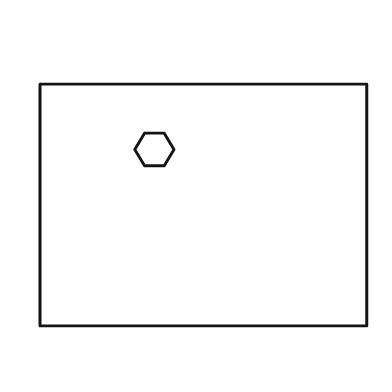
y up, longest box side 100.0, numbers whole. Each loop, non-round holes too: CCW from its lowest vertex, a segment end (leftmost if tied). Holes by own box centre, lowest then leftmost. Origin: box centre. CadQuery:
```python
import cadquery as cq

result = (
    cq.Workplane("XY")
    .moveTo(-50.0, -37.0)
    .lineTo(50.0, -37.0)
    .lineTo(50.0, 37.0)
    .lineTo(-50.0, 37.0)
    .close()
    .moveTo(-18.0, 12.0)
    .lineTo(-12.0, 12.0)
    .lineTo(-9.0, 17.0)
    .lineTo(-12.0, 22.0)
    .lineTo(-18.0, 22.0)
    .lineTo(-21.0, 17.0)
    .close()
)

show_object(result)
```